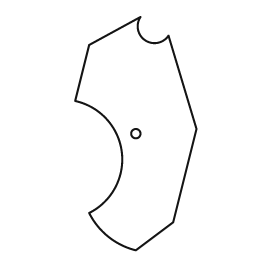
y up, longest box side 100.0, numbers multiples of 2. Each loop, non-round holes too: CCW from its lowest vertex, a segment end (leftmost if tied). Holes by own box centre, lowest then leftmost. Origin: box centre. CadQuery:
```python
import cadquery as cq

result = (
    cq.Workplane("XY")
    .moveTo(0.0, -50.0)
    .lineTo(16.0, -38.0)
    .lineTo(26.0, 2.0)
    .lineTo(14.0, 42.0)
    .threePointArc((4.0, 40.0), (2.0, 50.0))
    .lineTo(-20.0, 38.0)
    .lineTo(-26.0, 14.0)
    .threePointArc((-6.0, -8.0), (-20.0, -34.0))
    .threePointArc((-12.0, -44.0), (0.0, -50.0))
    .close()
    .moveTo(0.0, 0.0)
    .circle(2.0)
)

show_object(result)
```